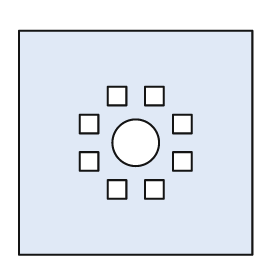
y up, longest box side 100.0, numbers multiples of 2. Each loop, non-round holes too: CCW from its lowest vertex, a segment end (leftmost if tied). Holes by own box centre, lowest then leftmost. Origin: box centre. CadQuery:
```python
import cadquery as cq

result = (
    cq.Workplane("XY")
    .moveTo(-50.0, -48.0)
    .lineTo(50.0, -48.0)
    .lineTo(50.0, 48.0)
    .lineTo(-50.0, 48.0)
    .close()
    .moveTo(-12.0, -24.0)
    .lineTo(-4.0, -24.0)
    .lineTo(-4.0, -16.0)
    .lineTo(-12.0, -16.0)
    .close()
    .moveTo(4.0, -24.0)
    .lineTo(12.0, -24.0)
    .lineTo(12.0, -16.0)
    .lineTo(4.0, -16.0)
    .close()
    .moveTo(-24.0, -12.0)
    .lineTo(-16.0, -12.0)
    .lineTo(-16.0, -4.0)
    .lineTo(-24.0, -4.0)
    .close()
    .moveTo(16.0, -12.0)
    .lineTo(24.0, -12.0)
    .lineTo(24.0, -4.0)
    .lineTo(16.0, -4.0)
    .close()
    .moveTo(0.0, 0.0)
    .circle(10.0)
    .moveTo(-24.0, 4.0)
    .lineTo(-16.0, 4.0)
    .lineTo(-16.0, 12.0)
    .lineTo(-24.0, 12.0)
    .close()
    .moveTo(16.0, 4.0)
    .lineTo(24.0, 4.0)
    .lineTo(24.0, 12.0)
    .lineTo(16.0, 12.0)
    .close()
    .moveTo(-12.0, 16.0)
    .lineTo(-4.0, 16.0)
    .lineTo(-4.0, 24.0)
    .lineTo(-12.0, 24.0)
    .close()
    .moveTo(4.0, 16.0)
    .lineTo(12.0, 16.0)
    .lineTo(12.0, 24.0)
    .lineTo(4.0, 24.0)
    .close()
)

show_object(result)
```